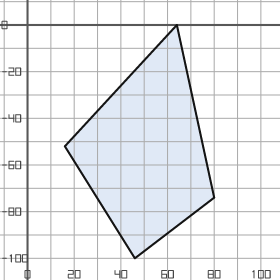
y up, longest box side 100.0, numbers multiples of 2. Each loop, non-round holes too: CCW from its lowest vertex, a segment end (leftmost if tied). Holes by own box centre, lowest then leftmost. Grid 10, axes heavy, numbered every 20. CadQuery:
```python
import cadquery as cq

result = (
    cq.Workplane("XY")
    .moveTo(46.0, -100.0)
    .lineTo(80.0, -74.0)
    .lineTo(64.0, 0.0)
    .lineTo(16.0, -52.0)
    .close()
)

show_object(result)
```